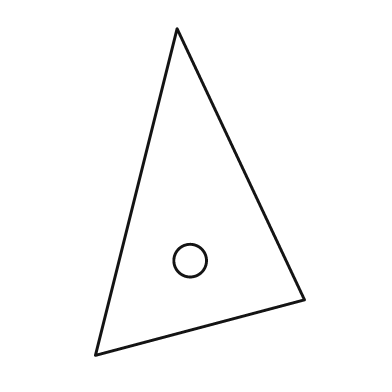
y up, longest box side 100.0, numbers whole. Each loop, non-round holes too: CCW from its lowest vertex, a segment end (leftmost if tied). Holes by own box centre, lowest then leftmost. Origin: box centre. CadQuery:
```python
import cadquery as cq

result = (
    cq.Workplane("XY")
    .moveTo(-32.0, -50.0)
    .lineTo(32.0, -33.0)
    .lineTo(-7.0, 50.0)
    .close()
    .moveTo(-3.0, -21.0)
    .circle(5.0)
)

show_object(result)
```